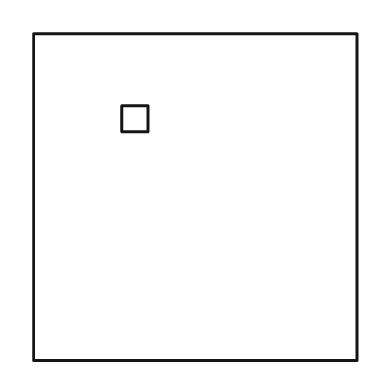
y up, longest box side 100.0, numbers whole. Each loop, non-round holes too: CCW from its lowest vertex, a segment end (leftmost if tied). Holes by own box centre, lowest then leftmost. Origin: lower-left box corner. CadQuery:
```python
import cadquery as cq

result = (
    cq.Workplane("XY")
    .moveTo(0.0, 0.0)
    .lineTo(99.0, 0.0)
    .lineTo(99.0, 100.0)
    .lineTo(0.0, 100.0)
    .close()
    .moveTo(27.0, 70.0)
    .lineTo(35.0, 70.0)
    .lineTo(35.0, 78.0)
    .lineTo(27.0, 78.0)
    .close()
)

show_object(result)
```